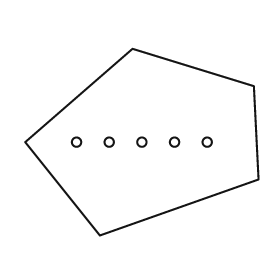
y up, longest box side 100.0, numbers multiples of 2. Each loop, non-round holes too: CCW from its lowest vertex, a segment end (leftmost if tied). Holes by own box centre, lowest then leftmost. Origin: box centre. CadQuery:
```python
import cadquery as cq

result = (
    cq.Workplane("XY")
    .moveTo(-18.0, -40.0)
    .lineTo(50.0, -16.0)
    .lineTo(48.0, 24.0)
    .lineTo(-4.0, 40.0)
    .lineTo(-50.0, 0.0)
    .close()
    .moveTo(-28.0, 0.0)
    .circle(2.0)
    .moveTo(-14.0, 0.0)
    .circle(2.0)
    .moveTo(0.0, 0.0)
    .circle(2.0)
    .moveTo(14.0, 0.0)
    .circle(2.0)
    .moveTo(28.0, 0.0)
    .circle(2.0)
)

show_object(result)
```